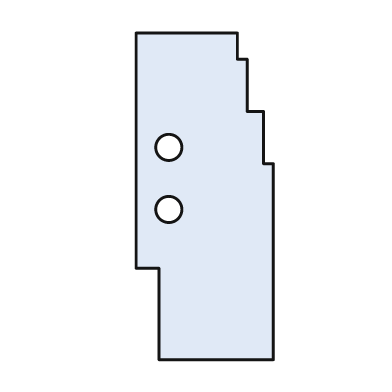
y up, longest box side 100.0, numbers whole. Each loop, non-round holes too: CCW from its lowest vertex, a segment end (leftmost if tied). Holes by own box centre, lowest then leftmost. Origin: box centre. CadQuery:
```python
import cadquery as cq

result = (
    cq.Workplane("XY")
    .moveTo(-14.0, -50.0)
    .lineTo(21.0, -50.0)
    .lineTo(21.0, 10.0)
    .lineTo(18.0, 10.0)
    .lineTo(18.0, 26.0)
    .lineTo(13.0, 26.0)
    .lineTo(13.0, 42.0)
    .lineTo(10.0, 42.0)
    .lineTo(10.0, 50.0)
    .lineTo(-21.0, 50.0)
    .lineTo(-21.0, -22.0)
    .lineTo(-14.0, -22.0)
    .close()
    .moveTo(-11.0, -4.0)
    .circle(4.0)
    .moveTo(-11.0, 15.0)
    .circle(4.0)
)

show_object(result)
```